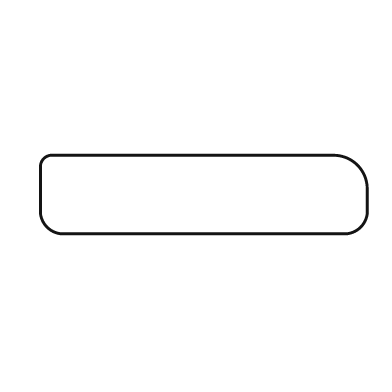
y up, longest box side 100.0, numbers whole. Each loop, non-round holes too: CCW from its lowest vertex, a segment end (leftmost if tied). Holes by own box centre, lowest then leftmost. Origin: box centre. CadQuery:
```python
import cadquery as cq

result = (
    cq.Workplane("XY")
    .moveTo(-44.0, -12.0)
    .lineTo(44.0, -12.0)
    .threePointArc((48.0, -10.0), (50.0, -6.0))
    .lineTo(50.0, 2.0)
    .threePointArc((47.0, 9.0), (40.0, 12.0))
    .lineTo(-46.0, 12.0)
    .threePointArc((-49.0, 11.0), (-50.0, 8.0))
    .lineTo(-50.0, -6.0)
    .threePointArc((-48.0, -10.0), (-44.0, -12.0))
    .close()
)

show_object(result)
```